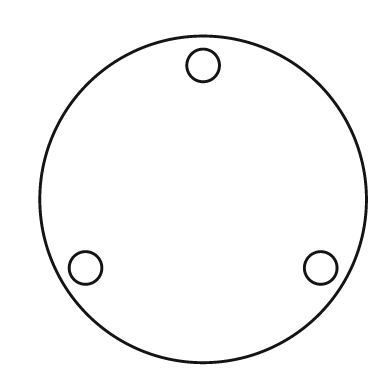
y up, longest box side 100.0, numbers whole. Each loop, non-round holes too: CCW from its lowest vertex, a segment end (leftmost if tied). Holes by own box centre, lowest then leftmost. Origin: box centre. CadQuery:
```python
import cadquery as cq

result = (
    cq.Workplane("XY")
    .moveTo(0.0, 0.0)
    .circle(50.0)
    .moveTo(-36.0, -21.0)
    .circle(5.0)
    .moveTo(36.0, -21.0)
    .circle(5.0)
    .moveTo(0.0, 41.0)
    .circle(5.0)
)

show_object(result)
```